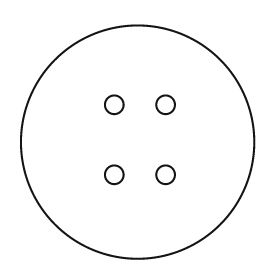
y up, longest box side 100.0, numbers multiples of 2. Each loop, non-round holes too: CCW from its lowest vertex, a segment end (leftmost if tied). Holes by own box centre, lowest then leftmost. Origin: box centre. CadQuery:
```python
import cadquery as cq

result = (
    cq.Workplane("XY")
    .moveTo(0.0, 0.0)
    .circle(50.0)
    .moveTo(-10.0, -14.0)
    .circle(4.0)
    .moveTo(12.0, -14.0)
    .circle(4.0)
    .moveTo(-10.0, 16.0)
    .circle(4.0)
    .moveTo(12.0, 16.0)
    .circle(4.0)
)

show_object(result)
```